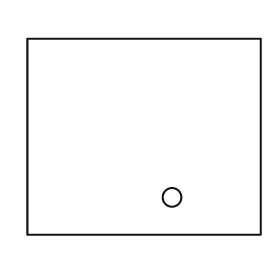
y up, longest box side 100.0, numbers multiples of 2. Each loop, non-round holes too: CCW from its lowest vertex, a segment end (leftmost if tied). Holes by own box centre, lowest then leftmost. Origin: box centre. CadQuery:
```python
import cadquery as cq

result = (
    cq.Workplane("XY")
    .moveTo(-50.0, -42.0)
    .lineTo(50.0, -42.0)
    .lineTo(50.0, 42.0)
    .lineTo(-50.0, 42.0)
    .close()
    .moveTo(12.0, -26.0)
    .circle(4.0)
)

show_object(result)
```